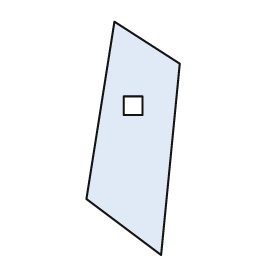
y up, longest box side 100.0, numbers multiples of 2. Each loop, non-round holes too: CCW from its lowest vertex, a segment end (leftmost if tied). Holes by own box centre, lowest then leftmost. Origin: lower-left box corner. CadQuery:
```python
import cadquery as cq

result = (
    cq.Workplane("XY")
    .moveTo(32.0, 0.0)
    .lineTo(40.0, 82.0)
    .lineTo(12.0, 100.0)
    .lineTo(0.0, 24.0)
    .close()
    .moveTo(16.0, 60.0)
    .lineTo(24.0, 60.0)
    .lineTo(24.0, 68.0)
    .lineTo(16.0, 68.0)
    .close()
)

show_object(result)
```